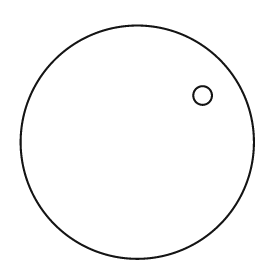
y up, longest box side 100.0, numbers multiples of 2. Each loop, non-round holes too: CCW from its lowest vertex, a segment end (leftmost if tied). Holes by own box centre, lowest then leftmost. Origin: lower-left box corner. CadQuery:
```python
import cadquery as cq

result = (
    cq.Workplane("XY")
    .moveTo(50.0, 50.0)
    .circle(50.0)
    .moveTo(78.0, 70.0)
    .circle(4.0)
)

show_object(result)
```